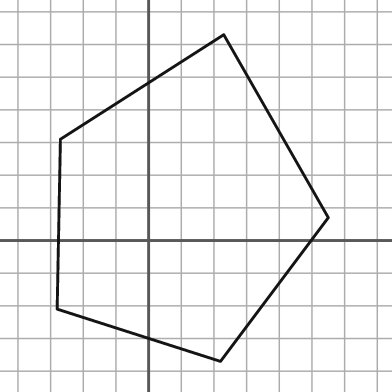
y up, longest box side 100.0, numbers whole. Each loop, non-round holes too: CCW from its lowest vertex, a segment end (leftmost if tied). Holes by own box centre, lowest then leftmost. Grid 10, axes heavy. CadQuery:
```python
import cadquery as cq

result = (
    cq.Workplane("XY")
    .moveTo(22.0, -37.0)
    .lineTo(55.0, 7.0)
    .lineTo(23.0, 63.0)
    .lineTo(-27.0, 31.0)
    .lineTo(-28.0, -21.0)
    .close()
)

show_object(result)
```